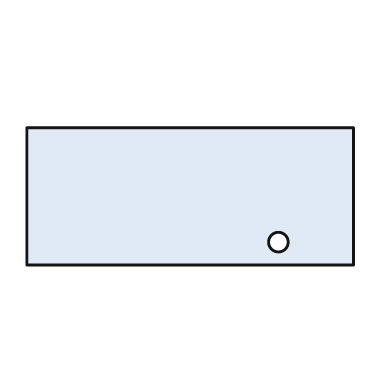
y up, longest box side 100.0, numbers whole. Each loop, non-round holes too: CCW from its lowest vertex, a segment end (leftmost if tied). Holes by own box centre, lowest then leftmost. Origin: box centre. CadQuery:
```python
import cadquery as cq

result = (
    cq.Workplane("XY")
    .moveTo(-50.0, -21.0)
    .lineTo(50.0, -21.0)
    .lineTo(50.0, 21.0)
    .lineTo(-50.0, 21.0)
    .close()
    .moveTo(27.0, -14.0)
    .circle(3.0)
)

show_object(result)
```